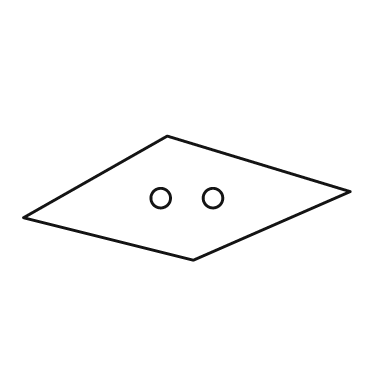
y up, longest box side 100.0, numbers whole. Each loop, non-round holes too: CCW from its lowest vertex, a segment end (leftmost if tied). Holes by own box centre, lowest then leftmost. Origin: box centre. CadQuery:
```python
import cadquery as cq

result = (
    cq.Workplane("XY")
    .moveTo(2.0, -19.0)
    .lineTo(50.0, 2.0)
    .lineTo(-6.0, 19.0)
    .lineTo(-50.0, -6.0)
    .close()
    .moveTo(-8.0, 0.0)
    .circle(3.0)
    .moveTo(8.0, 0.0)
    .circle(3.0)
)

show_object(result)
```